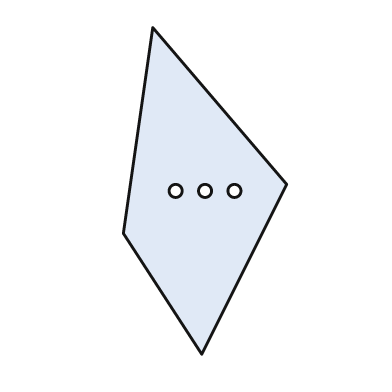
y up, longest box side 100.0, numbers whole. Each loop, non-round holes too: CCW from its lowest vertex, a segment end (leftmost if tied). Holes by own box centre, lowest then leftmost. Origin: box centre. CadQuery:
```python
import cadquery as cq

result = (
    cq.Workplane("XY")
    .moveTo(-1.0, -50.0)
    .lineTo(25.0, 2.0)
    .lineTo(-16.0, 50.0)
    .lineTo(-25.0, -13.0)
    .close()
    .moveTo(-9.0, 0.0)
    .circle(2.0)
    .moveTo(0.0, 0.0)
    .circle(2.0)
    .moveTo(9.0, 0.0)
    .circle(2.0)
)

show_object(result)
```